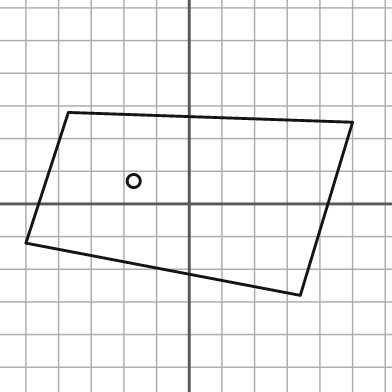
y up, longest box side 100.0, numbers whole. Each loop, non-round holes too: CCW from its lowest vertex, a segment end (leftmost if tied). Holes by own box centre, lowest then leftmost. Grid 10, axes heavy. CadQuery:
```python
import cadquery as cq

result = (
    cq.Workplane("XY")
    .moveTo(34.0, -28.0)
    .lineTo(50.0, 25.0)
    .lineTo(-37.0, 28.0)
    .lineTo(-50.0, -12.0)
    .close()
    .moveTo(-17.0, 7.0)
    .circle(2.0)
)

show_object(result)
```